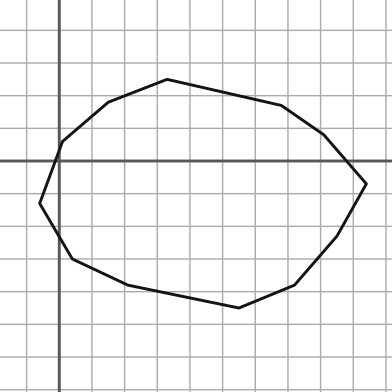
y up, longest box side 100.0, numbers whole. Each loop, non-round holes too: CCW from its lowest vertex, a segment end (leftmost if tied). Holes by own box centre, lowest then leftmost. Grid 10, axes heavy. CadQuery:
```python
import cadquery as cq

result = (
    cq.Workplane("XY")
    .moveTo(55.0, -45.0)
    .lineTo(72.0, -38.0)
    .lineTo(85.0, -23.0)
    .lineTo(94.0, -7.0)
    .lineTo(81.0, 8.0)
    .lineTo(68.0, 17.0)
    .lineTo(33.0, 25.0)
    .lineTo(15.0, 18.0)
    .lineTo(1.0, 6.0)
    .lineTo(-6.0, -13.0)
    .lineTo(4.0, -30.0)
    .lineTo(21.0, -38.0)
    .close()
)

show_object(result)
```